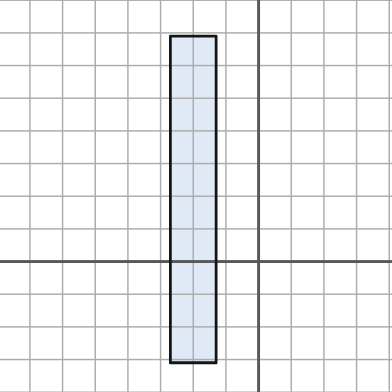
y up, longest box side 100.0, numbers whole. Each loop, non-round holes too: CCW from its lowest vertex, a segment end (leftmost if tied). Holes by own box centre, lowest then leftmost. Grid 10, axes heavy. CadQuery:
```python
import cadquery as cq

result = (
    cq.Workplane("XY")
    .moveTo(-27.0, -31.0)
    .lineTo(-13.0, -31.0)
    .lineTo(-13.0, 69.0)
    .lineTo(-27.0, 69.0)
    .close()
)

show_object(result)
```